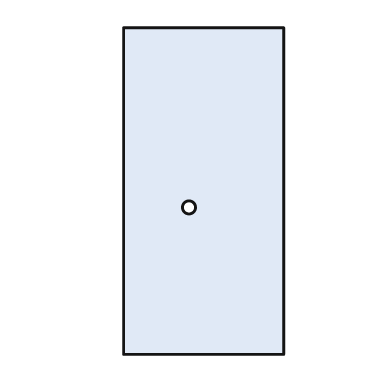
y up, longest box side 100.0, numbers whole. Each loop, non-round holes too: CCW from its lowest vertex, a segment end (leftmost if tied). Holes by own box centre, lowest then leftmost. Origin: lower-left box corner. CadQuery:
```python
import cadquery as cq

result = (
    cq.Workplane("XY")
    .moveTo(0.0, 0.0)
    .lineTo(49.0, 0.0)
    .lineTo(49.0, 100.0)
    .lineTo(0.0, 100.0)
    .close()
    .moveTo(20.0, 45.0)
    .circle(2.0)
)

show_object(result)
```